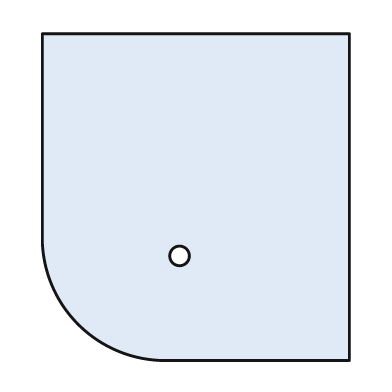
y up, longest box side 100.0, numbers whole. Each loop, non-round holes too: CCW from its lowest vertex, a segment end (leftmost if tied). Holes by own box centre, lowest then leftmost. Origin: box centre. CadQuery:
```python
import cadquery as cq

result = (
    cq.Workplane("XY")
    .moveTo(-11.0, -50.0)
    .lineTo(47.0, -50.0)
    .lineTo(47.0, 50.0)
    .lineTo(-47.0, 50.0)
    .lineTo(-47.0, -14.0)
    .threePointArc((-36.0, -39.0), (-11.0, -50.0))
    .close()
    .moveTo(-5.0, -18.0)
    .circle(3.0)
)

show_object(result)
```